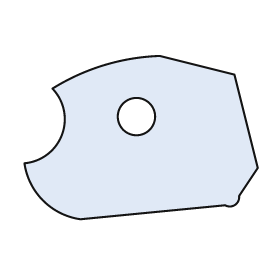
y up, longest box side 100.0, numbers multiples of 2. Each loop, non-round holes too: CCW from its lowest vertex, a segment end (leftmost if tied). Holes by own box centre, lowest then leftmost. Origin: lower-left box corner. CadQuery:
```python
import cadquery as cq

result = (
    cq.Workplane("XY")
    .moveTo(24.0, 0.0)
    .lineTo(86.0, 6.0)
    .threePointArc((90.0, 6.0), (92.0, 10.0))
    .lineTo(100.0, 22.0)
    .lineTo(90.0, 62.0)
    .lineTo(58.0, 70.0)
    .threePointArc((34.0, 66.0), (12.0, 56.0))
    .threePointArc((16.0, 36.0), (0.0, 24.0))
    .threePointArc((8.0, 8.0), (24.0, 0.0))
    .close()
    .moveTo(48.0, 44.0)
    .circle(8.0)
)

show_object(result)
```